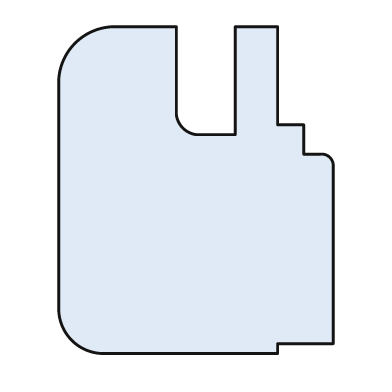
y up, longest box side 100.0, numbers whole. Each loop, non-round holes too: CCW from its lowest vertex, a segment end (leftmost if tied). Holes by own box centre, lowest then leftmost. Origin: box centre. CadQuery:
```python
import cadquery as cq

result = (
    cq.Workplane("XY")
    .moveTo(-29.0, -50.0)
    .lineTo(25.0, -50.0)
    .lineTo(25.0, -47.0)
    .lineTo(42.0, -47.0)
    .lineTo(42.0, 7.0)
    .threePointArc((41.0, 10.0), (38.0, 11.0))
    .lineTo(33.0, 11.0)
    .lineTo(33.0, 20.0)
    .lineTo(25.0, 20.0)
    .lineTo(25.0, 50.0)
    .lineTo(12.0, 50.0)
    .lineTo(12.0, 17.0)
    .lineTo(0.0, 17.0)
    .threePointArc((-4.0, 19.0), (-6.0, 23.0))
    .lineTo(-6.0, 50.0)
    .lineTo(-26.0, 50.0)
    .threePointArc((-37.0, 45.0), (-42.0, 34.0))
    .lineTo(-42.0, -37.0)
    .threePointArc((-38.0, -46.0), (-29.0, -50.0))
    .close()
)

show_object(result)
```